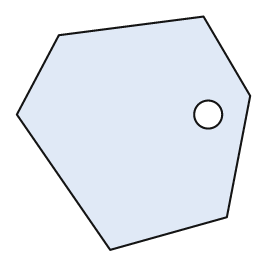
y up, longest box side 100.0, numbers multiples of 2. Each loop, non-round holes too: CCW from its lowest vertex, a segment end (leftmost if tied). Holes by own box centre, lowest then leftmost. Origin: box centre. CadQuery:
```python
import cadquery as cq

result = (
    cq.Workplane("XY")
    .moveTo(-10.0, -50.0)
    .lineTo(40.0, -36.0)
    .lineTo(50.0, 16.0)
    .lineTo(30.0, 50.0)
    .lineTo(-32.0, 42.0)
    .lineTo(-50.0, 8.0)
    .close()
    .moveTo(32.0, 8.0)
    .circle(6.0)
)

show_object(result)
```